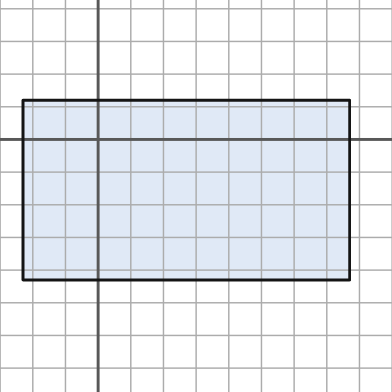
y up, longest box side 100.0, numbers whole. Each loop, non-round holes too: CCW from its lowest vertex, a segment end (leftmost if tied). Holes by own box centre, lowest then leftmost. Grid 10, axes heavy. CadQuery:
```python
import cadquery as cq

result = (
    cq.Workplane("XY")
    .moveTo(-23.0, -43.0)
    .lineTo(77.0, -43.0)
    .lineTo(77.0, 12.0)
    .lineTo(-23.0, 12.0)
    .close()
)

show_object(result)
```